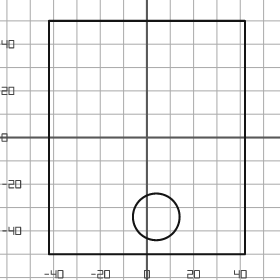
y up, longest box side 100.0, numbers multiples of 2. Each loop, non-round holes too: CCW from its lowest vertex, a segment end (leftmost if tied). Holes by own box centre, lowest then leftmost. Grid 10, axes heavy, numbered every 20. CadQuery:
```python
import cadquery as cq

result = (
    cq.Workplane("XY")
    .moveTo(-42.0, -50.0)
    .lineTo(42.0, -50.0)
    .lineTo(42.0, 50.0)
    .lineTo(-42.0, 50.0)
    .close()
    .moveTo(4.0, -34.0)
    .circle(10.0)
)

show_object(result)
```